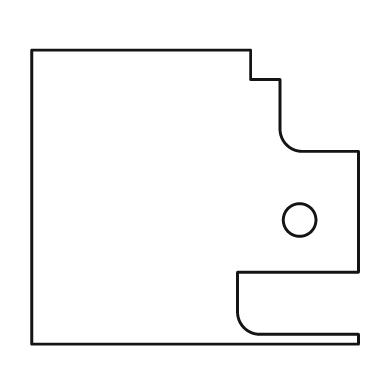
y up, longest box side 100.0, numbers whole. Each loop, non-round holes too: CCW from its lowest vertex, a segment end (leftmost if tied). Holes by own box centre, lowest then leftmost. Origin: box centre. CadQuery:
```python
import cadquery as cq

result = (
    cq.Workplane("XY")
    .moveTo(-50.0, -45.0)
    .lineTo(50.0, -45.0)
    .lineTo(50.0, -42.0)
    .lineTo(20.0, -42.0)
    .threePointArc((15.0, -40.0), (13.0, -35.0))
    .lineTo(13.0, -23.0)
    .lineTo(50.0, -23.0)
    .lineTo(50.0, 14.0)
    .lineTo(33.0, 14.0)
    .threePointArc((28.0, 16.0), (26.0, 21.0))
    .lineTo(26.0, 36.0)
    .lineTo(17.0, 36.0)
    .lineTo(17.0, 45.0)
    .lineTo(-50.0, 45.0)
    .close()
    .moveTo(32.0, -7.0)
    .circle(5.0)
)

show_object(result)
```